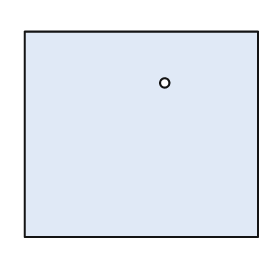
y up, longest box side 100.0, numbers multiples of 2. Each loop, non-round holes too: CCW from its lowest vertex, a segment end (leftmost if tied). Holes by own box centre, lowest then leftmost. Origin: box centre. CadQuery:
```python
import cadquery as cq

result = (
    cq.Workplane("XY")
    .moveTo(-50.0, -44.0)
    .lineTo(50.0, -44.0)
    .lineTo(50.0, 44.0)
    .lineTo(-50.0, 44.0)
    .close()
    .moveTo(10.0, 22.0)
    .circle(2.0)
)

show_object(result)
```